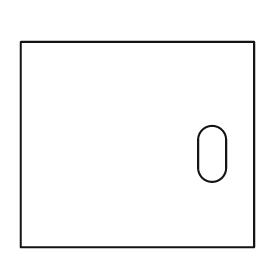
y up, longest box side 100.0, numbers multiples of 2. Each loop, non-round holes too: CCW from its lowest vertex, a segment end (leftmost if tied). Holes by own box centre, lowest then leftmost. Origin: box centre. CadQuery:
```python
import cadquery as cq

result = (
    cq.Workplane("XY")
    .moveTo(-50.0, -44.0)
    .lineTo(50.0, -44.0)
    .lineTo(50.0, 44.0)
    .lineTo(-50.0, 44.0)
    .close()
    .moveTo(26.0, -10.0)
    .threePointArc((32.0, -16.0), (38.0, -10.0))
    .lineTo(38.0, 2.0)
    .threePointArc((32.0, 8.0), (26.0, 2.0))
    .close()
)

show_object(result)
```